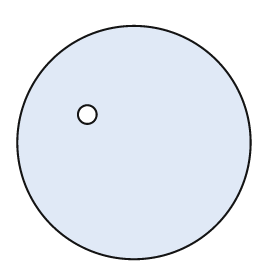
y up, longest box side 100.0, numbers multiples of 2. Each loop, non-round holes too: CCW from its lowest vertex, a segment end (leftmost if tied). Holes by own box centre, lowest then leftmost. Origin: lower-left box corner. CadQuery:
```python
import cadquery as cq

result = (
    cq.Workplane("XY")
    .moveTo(50.0, 50.0)
    .circle(50.0)
    .moveTo(30.0, 62.0)
    .circle(4.0)
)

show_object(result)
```